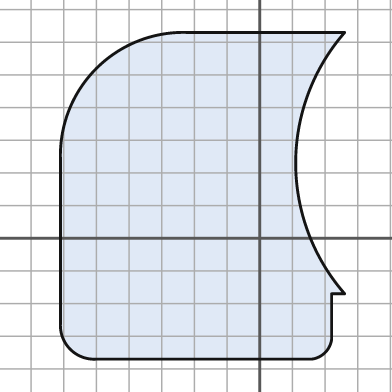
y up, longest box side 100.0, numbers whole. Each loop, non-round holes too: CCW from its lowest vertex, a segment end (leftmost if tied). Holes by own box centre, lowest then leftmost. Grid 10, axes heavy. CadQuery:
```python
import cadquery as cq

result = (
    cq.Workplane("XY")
    .moveTo(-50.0, -37.0)
    .lineTo(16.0, -37.0)
    .threePointArc((20.0, -35.0), (22.0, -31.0))
    .lineTo(22.0, -17.0)
    .lineTo(26.0, -17.0)
    .threePointArc((11.0, 23.0), (26.0, 63.0))
    .lineTo(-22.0, 63.0)
    .threePointArc((-50.0, 52.0), (-61.0, 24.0))
    .lineTo(-61.0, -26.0)
    .threePointArc((-58.0, -34.0), (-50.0, -37.0))
    .close()
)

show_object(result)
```